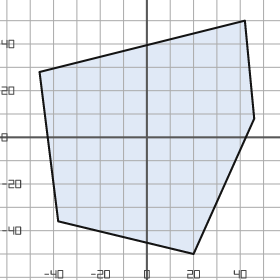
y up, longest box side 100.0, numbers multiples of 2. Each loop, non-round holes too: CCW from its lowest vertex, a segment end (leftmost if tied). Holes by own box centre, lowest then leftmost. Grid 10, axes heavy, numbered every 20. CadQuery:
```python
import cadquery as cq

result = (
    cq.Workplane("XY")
    .moveTo(20.0, -50.0)
    .lineTo(46.0, 8.0)
    .lineTo(42.0, 50.0)
    .lineTo(-46.0, 28.0)
    .lineTo(-38.0, -36.0)
    .close()
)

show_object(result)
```